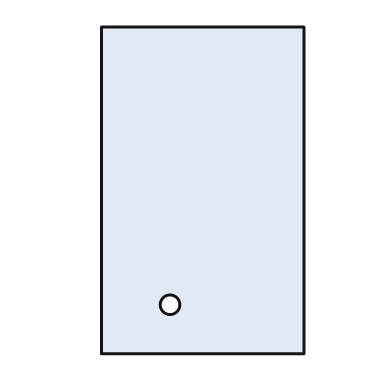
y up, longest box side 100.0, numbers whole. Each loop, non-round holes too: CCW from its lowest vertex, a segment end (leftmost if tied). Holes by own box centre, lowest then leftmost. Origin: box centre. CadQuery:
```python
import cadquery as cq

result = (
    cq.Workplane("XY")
    .moveTo(-31.0, -50.0)
    .lineTo(31.0, -50.0)
    .lineTo(31.0, 50.0)
    .lineTo(-31.0, 50.0)
    .close()
    .moveTo(-10.0, -35.0)
    .circle(3.0)
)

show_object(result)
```